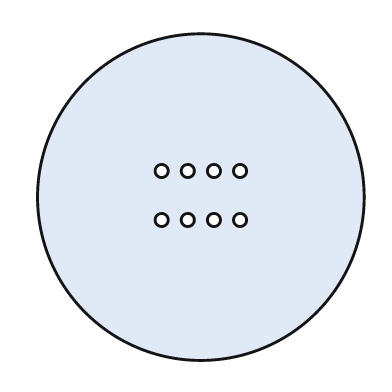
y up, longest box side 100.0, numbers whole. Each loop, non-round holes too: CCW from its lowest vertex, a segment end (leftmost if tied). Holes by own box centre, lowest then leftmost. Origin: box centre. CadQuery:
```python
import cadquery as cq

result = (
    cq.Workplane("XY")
    .moveTo(0.0, 0.0)
    .circle(50.0)
    .moveTo(-12.0, -7.0)
    .circle(2.0)
    .moveTo(-4.0, -7.0)
    .circle(2.0)
    .moveTo(4.0, -7.0)
    .circle(2.0)
    .moveTo(12.0, -7.0)
    .circle(2.0)
    .moveTo(-12.0, 8.0)
    .circle(2.0)
    .moveTo(-4.0, 8.0)
    .circle(2.0)
    .moveTo(4.0, 8.0)
    .circle(2.0)
    .moveTo(12.0, 8.0)
    .circle(2.0)
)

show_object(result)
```